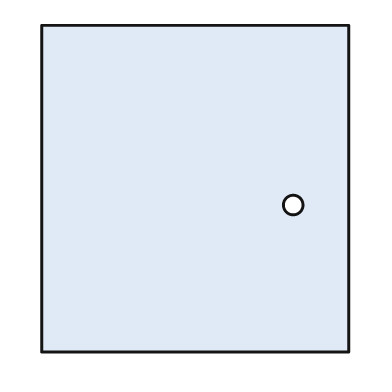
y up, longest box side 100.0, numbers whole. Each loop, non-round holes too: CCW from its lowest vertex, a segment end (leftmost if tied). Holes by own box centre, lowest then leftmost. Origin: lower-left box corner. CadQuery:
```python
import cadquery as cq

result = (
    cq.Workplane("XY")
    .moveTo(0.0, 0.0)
    .lineTo(94.0, 0.0)
    .lineTo(94.0, 100.0)
    .lineTo(0.0, 100.0)
    .close()
    .moveTo(77.0, 45.0)
    .circle(3.0)
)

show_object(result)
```